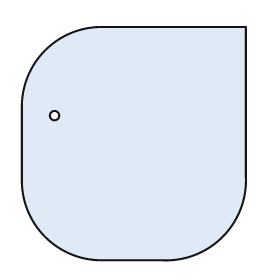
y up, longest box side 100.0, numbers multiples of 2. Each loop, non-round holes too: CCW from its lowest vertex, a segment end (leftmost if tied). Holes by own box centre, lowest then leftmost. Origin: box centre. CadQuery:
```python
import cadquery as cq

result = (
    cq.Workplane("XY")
    .moveTo(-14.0, -50.0)
    .lineTo(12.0, -50.0)
    .threePointArc((38.0, -40.0), (48.0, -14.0))
    .lineTo(48.0, 50.0)
    .lineTo(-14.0, 50.0)
    .threePointArc((-38.0, 40.0), (-48.0, 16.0))
    .lineTo(-48.0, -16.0)
    .threePointArc((-38.0, -40.0), (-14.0, -50.0))
    .close()
    .moveTo(-34.0, 12.0)
    .circle(2.0)
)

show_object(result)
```